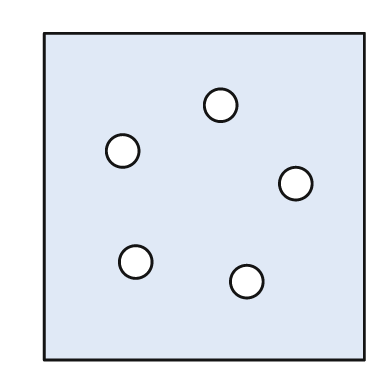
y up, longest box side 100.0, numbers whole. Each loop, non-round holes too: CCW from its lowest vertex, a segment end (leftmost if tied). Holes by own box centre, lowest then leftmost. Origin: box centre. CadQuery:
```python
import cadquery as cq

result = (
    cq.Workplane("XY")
    .moveTo(-49.0, -50.0)
    .lineTo(49.0, -50.0)
    .lineTo(49.0, 50.0)
    .lineTo(-49.0, 50.0)
    .close()
    .moveTo(13.0, -26.0)
    .circle(5.0)
    .moveTo(-21.0, -20.0)
    .circle(5.0)
    .moveTo(28.0, 4.0)
    .circle(5.0)
    .moveTo(-25.0, 14.0)
    .circle(5.0)
    .moveTo(5.0, 28.0)
    .circle(5.0)
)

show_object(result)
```